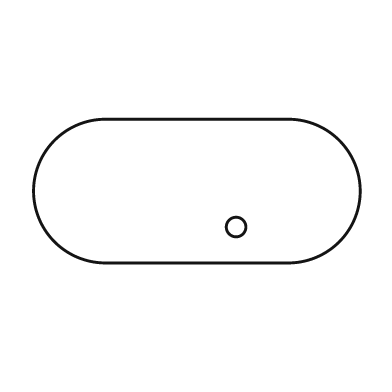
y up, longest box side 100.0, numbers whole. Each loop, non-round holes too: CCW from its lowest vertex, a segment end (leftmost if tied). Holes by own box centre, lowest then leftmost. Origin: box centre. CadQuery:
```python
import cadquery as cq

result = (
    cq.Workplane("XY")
    .moveTo(-28.0, -22.0)
    .lineTo(28.0, -22.0)
    .threePointArc((50.0, 0.0), (28.0, 22.0))
    .lineTo(-28.0, 22.0)
    .threePointArc((-50.0, 0.0), (-28.0, -22.0))
    .close()
    .moveTo(12.0, -11.0)
    .circle(3.0)
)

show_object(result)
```